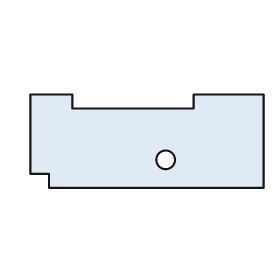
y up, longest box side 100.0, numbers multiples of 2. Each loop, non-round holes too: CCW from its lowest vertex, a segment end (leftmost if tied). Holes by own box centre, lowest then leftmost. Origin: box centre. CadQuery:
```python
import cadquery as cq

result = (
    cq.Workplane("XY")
    .moveTo(-42.0, -20.0)
    .lineTo(50.0, -20.0)
    .lineTo(50.0, 20.0)
    .lineTo(20.0, 20.0)
    .lineTo(20.0, 14.0)
    .lineTo(-32.0, 14.0)
    .lineTo(-32.0, 20.0)
    .lineTo(-50.0, 20.0)
    .lineTo(-50.0, -14.0)
    .lineTo(-42.0, -14.0)
    .close()
    .moveTo(8.0, -8.0)
    .circle(4.0)
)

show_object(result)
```